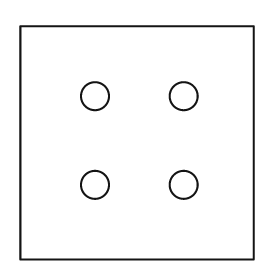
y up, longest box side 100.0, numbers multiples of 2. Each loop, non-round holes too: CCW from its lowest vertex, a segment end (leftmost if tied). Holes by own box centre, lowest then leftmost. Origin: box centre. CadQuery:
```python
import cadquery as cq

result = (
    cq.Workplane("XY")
    .moveTo(-50.0, -50.0)
    .lineTo(50.0, -50.0)
    .lineTo(50.0, 50.0)
    .lineTo(-50.0, 50.0)
    .close()
    .moveTo(-18.0, -18.0)
    .circle(6.0)
    .moveTo(20.0, -18.0)
    .circle(6.0)
    .moveTo(-18.0, 20.0)
    .circle(6.0)
    .moveTo(20.0, 20.0)
    .circle(6.0)
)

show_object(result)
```